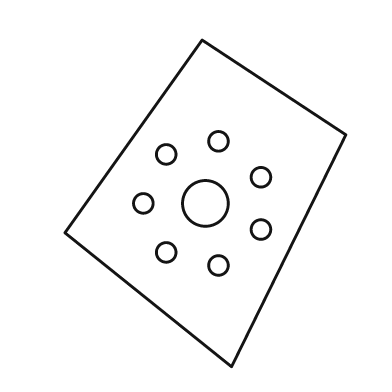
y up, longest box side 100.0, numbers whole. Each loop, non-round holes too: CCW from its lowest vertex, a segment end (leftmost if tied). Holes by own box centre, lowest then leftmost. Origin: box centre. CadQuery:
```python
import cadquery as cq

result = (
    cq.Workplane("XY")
    .moveTo(8.0, -50.0)
    .lineTo(43.0, 21.0)
    .lineTo(-1.0, 50.0)
    .lineTo(-43.0, -9.0)
    .close()
    .moveTo(4.0, -19.0)
    .circle(3.0)
    .moveTo(-12.0, -15.0)
    .circle(3.0)
    .moveTo(17.0, -8.0)
    .circle(3.0)
    .moveTo(-19.0, 0.0)
    .circle(3.0)
    .moveTo(0.0, 0.0)
    .circle(7.0)
    .moveTo(17.0, 8.0)
    .circle(3.0)
    .moveTo(-12.0, 15.0)
    .circle(3.0)
    .moveTo(4.0, 19.0)
    .circle(3.0)
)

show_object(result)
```